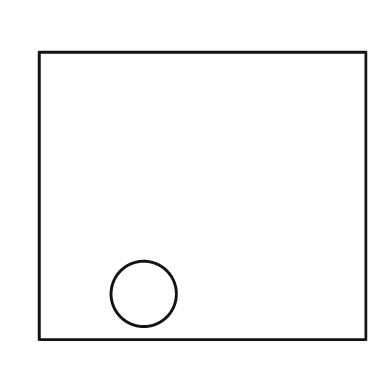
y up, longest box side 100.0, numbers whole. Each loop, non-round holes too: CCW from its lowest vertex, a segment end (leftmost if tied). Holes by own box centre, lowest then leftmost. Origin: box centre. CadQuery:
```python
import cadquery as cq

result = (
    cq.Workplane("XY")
    .moveTo(-50.0, -44.0)
    .lineTo(50.0, -44.0)
    .lineTo(50.0, 44.0)
    .lineTo(-50.0, 44.0)
    .close()
    .moveTo(-18.0, -30.0)
    .circle(10.0)
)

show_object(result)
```